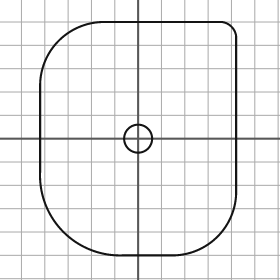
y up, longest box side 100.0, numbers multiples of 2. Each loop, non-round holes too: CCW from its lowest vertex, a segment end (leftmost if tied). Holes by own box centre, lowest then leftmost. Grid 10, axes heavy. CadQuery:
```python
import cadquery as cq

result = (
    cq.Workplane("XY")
    .moveTo(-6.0, -50.0)
    .lineTo(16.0, -50.0)
    .threePointArc((34.0, -42.0), (42.0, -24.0))
    .lineTo(42.0, 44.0)
    .threePointArc((40.0, 48.0), (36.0, 50.0))
    .lineTo(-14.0, 50.0)
    .threePointArc((-34.0, 42.0), (-42.0, 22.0))
    .lineTo(-42.0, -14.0)
    .threePointArc((-32.0, -40.0), (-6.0, -50.0))
    .close()
    .moveTo(0.0, 0.0)
    .circle(6.0)
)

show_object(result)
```